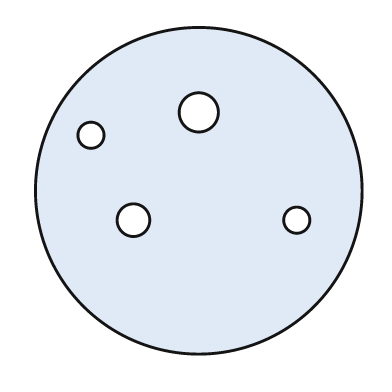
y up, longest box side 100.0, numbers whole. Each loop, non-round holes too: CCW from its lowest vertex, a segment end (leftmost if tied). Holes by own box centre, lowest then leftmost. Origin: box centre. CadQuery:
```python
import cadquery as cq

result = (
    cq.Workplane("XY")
    .moveTo(0.0, 0.0)
    .circle(50.0)
    .moveTo(-20.0, -9.0)
    .circle(5.0)
    .moveTo(30.0, -9.0)
    .circle(4.0)
    .moveTo(-33.0, 17.0)
    .circle(4.0)
    .moveTo(0.0, 24.0)
    .circle(6.0)
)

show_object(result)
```